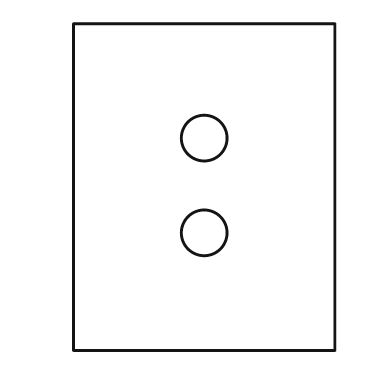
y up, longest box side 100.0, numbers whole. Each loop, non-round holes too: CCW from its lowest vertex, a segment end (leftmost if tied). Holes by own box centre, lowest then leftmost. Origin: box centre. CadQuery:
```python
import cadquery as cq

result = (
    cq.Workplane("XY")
    .moveTo(-40.0, -50.0)
    .lineTo(40.0, -50.0)
    .lineTo(40.0, 50.0)
    .lineTo(-40.0, 50.0)
    .close()
    .moveTo(0.0, -14.0)
    .circle(7.0)
    .moveTo(0.0, 15.0)
    .circle(7.0)
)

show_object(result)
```